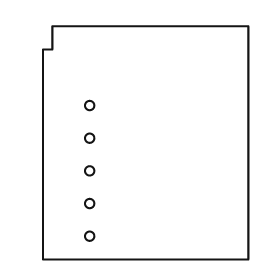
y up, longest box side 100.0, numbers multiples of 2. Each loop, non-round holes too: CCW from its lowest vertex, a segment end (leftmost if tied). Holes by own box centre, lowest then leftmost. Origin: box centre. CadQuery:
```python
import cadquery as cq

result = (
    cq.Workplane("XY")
    .moveTo(-44.0, -50.0)
    .lineTo(44.0, -50.0)
    .lineTo(44.0, 50.0)
    .lineTo(-40.0, 50.0)
    .lineTo(-40.0, 40.0)
    .lineTo(-44.0, 40.0)
    .close()
    .moveTo(-24.0, -40.0)
    .circle(2.0)
    .moveTo(-24.0, -26.0)
    .circle(2.0)
    .moveTo(-24.0, -12.0)
    .circle(2.0)
    .moveTo(-24.0, 2.0)
    .circle(2.0)
    .moveTo(-24.0, 16.0)
    .circle(2.0)
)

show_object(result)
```